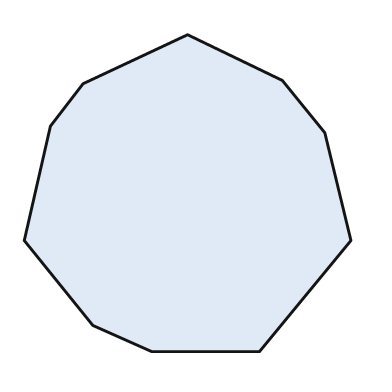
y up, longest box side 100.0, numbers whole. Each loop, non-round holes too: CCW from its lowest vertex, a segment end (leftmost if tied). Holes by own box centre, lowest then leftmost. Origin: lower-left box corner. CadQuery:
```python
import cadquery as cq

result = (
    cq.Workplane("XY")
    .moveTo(39.0, 0.0)
    .lineTo(72.0, 0.0)
    .lineTo(100.0, 34.0)
    .lineTo(92.0, 67.0)
    .lineTo(79.0, 83.0)
    .lineTo(50.0, 97.0)
    .lineTo(18.0, 82.0)
    .lineTo(8.0, 69.0)
    .lineTo(0.0, 34.0)
    .lineTo(21.0, 8.0)
    .close()
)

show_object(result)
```